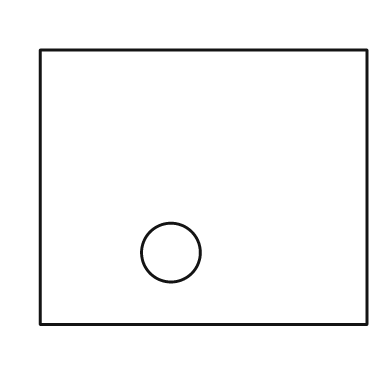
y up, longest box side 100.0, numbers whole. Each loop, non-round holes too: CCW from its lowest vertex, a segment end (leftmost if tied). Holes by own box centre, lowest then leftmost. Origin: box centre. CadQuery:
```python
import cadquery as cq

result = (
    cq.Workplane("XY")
    .moveTo(-50.0, -42.0)
    .lineTo(50.0, -42.0)
    .lineTo(50.0, 42.0)
    .lineTo(-50.0, 42.0)
    .close()
    .moveTo(-10.0, -20.0)
    .circle(9.0)
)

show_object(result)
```